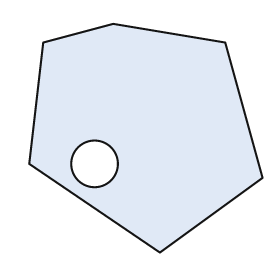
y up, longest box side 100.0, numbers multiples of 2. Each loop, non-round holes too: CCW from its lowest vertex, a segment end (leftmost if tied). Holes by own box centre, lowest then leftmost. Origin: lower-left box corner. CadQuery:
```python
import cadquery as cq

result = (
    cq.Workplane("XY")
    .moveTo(56.0, 0.0)
    .lineTo(100.0, 32.0)
    .lineTo(84.0, 90.0)
    .lineTo(36.0, 98.0)
    .lineTo(6.0, 90.0)
    .lineTo(0.0, 38.0)
    .close()
    .moveTo(28.0, 38.0)
    .circle(10.0)
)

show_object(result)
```